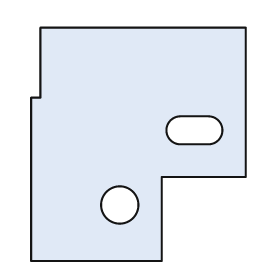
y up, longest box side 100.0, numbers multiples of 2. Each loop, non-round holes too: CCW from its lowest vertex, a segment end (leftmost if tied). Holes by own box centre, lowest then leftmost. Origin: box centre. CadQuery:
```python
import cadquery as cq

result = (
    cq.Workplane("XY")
    .moveTo(-46.0, -50.0)
    .lineTo(10.0, -50.0)
    .lineTo(10.0, -14.0)
    .lineTo(46.0, -14.0)
    .lineTo(46.0, 50.0)
    .lineTo(-42.0, 50.0)
    .lineTo(-42.0, 20.0)
    .lineTo(-46.0, 20.0)
    .close()
    .moveTo(-8.0, -26.0)
    .circle(8.0)
    .moveTo(18.0, 0.0)
    .lineTo(30.0, 0.0)
    .threePointArc((36.0, 6.0), (30.0, 12.0))
    .lineTo(18.0, 12.0)
    .threePointArc((12.0, 6.0), (18.0, 0.0))
    .close()
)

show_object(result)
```